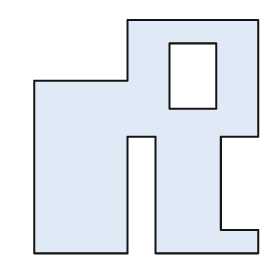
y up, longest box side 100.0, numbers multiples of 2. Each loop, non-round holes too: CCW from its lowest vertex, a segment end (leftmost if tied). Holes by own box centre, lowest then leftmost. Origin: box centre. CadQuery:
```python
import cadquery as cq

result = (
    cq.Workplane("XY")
    .moveTo(-48.0, -50.0)
    .lineTo(-8.0, -50.0)
    .lineTo(-8.0, 0.0)
    .lineTo(4.0, 0.0)
    .lineTo(4.0, -50.0)
    .lineTo(48.0, -50.0)
    .lineTo(48.0, -40.0)
    .lineTo(32.0, -40.0)
    .lineTo(32.0, 0.0)
    .lineTo(48.0, 0.0)
    .lineTo(48.0, 50.0)
    .lineTo(-8.0, 50.0)
    .lineTo(-8.0, 24.0)
    .lineTo(-48.0, 24.0)
    .close()
    .moveTo(10.0, 12.0)
    .lineTo(30.0, 12.0)
    .lineTo(30.0, 40.0)
    .lineTo(10.0, 40.0)
    .close()
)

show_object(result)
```